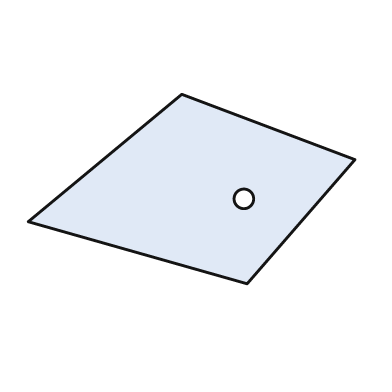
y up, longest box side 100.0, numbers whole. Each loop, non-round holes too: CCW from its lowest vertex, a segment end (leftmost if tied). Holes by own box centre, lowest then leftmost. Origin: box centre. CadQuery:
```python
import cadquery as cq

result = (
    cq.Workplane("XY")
    .moveTo(17.0, -29.0)
    .lineTo(50.0, 9.0)
    .lineTo(-3.0, 29.0)
    .lineTo(-50.0, -10.0)
    .close()
    .moveTo(16.0, -3.0)
    .circle(3.0)
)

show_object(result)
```